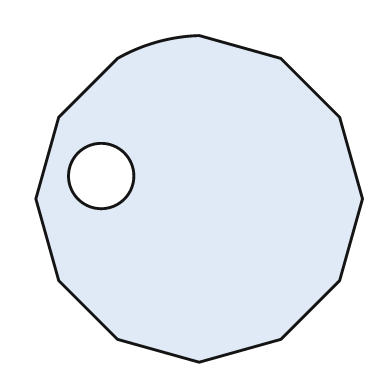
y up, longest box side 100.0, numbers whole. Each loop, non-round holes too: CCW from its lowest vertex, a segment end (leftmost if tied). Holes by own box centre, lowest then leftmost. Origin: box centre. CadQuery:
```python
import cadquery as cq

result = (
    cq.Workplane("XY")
    .moveTo(0.0, -50.0)
    .lineTo(25.0, -43.0)
    .lineTo(43.0, -25.0)
    .lineTo(50.0, 0.0)
    .lineTo(43.0, 25.0)
    .lineTo(25.0, 43.0)
    .lineTo(0.0, 50.0)
    .threePointArc((-13.0, 48.0), (-25.0, 43.0))
    .lineTo(-43.0, 25.0)
    .lineTo(-50.0, 0.0)
    .lineTo(-43.0, -25.0)
    .lineTo(-25.0, -43.0)
    .close()
    .moveTo(-30.0, 7.0)
    .circle(10.0)
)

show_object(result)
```